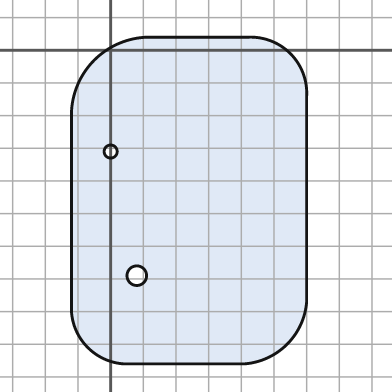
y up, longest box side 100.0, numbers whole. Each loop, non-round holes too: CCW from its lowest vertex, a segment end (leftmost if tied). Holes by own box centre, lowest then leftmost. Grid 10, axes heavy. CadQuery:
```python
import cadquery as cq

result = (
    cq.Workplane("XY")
    .moveTo(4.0, -96.0)
    .lineTo(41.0, -96.0)
    .threePointArc((54.0, -90.0), (60.0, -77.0))
    .lineTo(60.0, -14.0)
    .threePointArc((55.0, -1.0), (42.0, 4.0))
    .lineTo(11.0, 4.0)
    .threePointArc((-5.0, -3.0), (-12.0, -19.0))
    .lineTo(-12.0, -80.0)
    .threePointArc((-7.0, -91.0), (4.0, -96.0))
    .close()
    .moveTo(8.0, -69.0)
    .circle(3.0)
    .moveTo(0.0, -31.0)
    .circle(2.0)
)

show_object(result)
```